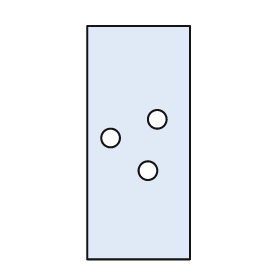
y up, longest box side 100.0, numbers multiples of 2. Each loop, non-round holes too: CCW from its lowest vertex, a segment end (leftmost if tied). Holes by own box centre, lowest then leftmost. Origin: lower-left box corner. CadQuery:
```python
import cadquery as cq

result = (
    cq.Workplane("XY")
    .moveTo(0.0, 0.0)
    .lineTo(44.0, 0.0)
    .lineTo(44.0, 100.0)
    .lineTo(0.0, 100.0)
    .close()
    .moveTo(26.0, 38.0)
    .circle(4.0)
    .moveTo(10.0, 52.0)
    .circle(4.0)
    .moveTo(30.0, 60.0)
    .circle(4.0)
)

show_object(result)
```